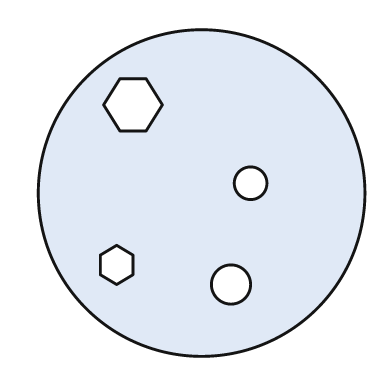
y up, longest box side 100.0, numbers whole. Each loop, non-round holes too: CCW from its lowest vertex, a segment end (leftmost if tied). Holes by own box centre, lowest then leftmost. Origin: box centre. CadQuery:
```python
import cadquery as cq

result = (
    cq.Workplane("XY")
    .moveTo(0.0, 0.0)
    .circle(50.0)
    .moveTo(9.0, -28.0)
    .circle(6.0)
    .moveTo(-26.0, -28.0)
    .lineTo(-21.0, -25.0)
    .lineTo(-21.0, -19.0)
    .lineTo(-26.0, -16.0)
    .lineTo(-31.0, -19.0)
    .lineTo(-31.0, -25.0)
    .close()
    .moveTo(15.0, 3.0)
    .circle(5.0)
    .moveTo(-25.0, 19.0)
    .lineTo(-17.0, 19.0)
    .lineTo(-12.0, 27.0)
    .lineTo(-17.0, 35.0)
    .lineTo(-25.0, 35.0)
    .lineTo(-30.0, 27.0)
    .close()
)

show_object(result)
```